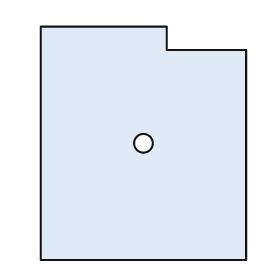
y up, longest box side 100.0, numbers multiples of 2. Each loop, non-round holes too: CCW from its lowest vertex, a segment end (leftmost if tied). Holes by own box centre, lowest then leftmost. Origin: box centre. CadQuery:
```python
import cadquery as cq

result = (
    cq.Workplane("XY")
    .moveTo(-44.0, -50.0)
    .lineTo(44.0, -50.0)
    .lineTo(44.0, 40.0)
    .lineTo(10.0, 40.0)
    .lineTo(10.0, 50.0)
    .lineTo(-44.0, 50.0)
    .close()
    .moveTo(0.0, 0.0)
    .circle(4.0)
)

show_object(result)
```